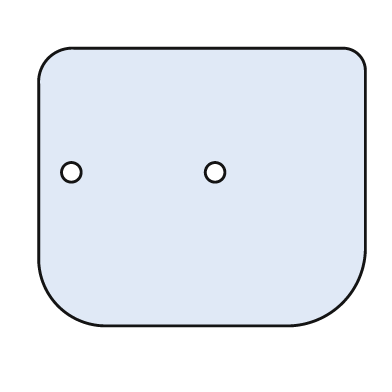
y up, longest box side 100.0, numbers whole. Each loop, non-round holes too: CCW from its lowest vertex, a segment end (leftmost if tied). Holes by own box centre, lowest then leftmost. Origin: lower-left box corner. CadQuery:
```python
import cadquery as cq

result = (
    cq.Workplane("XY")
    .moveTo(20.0, 0.0)
    .lineTo(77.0, 0.0)
    .threePointArc((93.0, 7.0), (100.0, 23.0))
    .lineTo(100.0, 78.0)
    .threePointArc((98.0, 83.0), (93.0, 85.0))
    .lineTo(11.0, 85.0)
    .threePointArc((3.0, 82.0), (0.0, 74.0))
    .lineTo(0.0, 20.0)
    .threePointArc((6.0, 6.0), (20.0, 0.0))
    .close()
    .moveTo(10.0, 47.0)
    .circle(3.0)
    .moveTo(54.0, 47.0)
    .circle(3.0)
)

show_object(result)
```